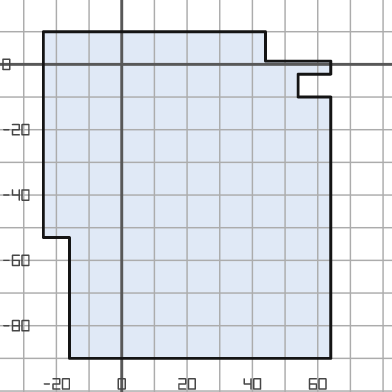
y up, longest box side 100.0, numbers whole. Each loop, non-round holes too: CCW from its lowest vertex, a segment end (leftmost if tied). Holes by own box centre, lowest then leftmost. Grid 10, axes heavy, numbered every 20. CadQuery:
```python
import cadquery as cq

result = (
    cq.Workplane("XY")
    .moveTo(-16.0, -90.0)
    .lineTo(64.0, -90.0)
    .lineTo(64.0, -10.0)
    .lineTo(54.0, -10.0)
    .lineTo(54.0, -3.0)
    .lineTo(64.0, -3.0)
    .lineTo(64.0, 1.0)
    .lineTo(44.0, 1.0)
    .lineTo(44.0, 10.0)
    .lineTo(-24.0, 10.0)
    .lineTo(-24.0, -53.0)
    .lineTo(-16.0, -53.0)
    .close()
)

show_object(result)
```